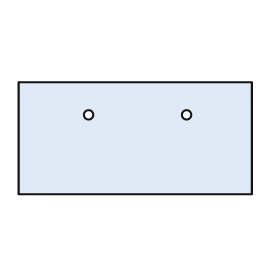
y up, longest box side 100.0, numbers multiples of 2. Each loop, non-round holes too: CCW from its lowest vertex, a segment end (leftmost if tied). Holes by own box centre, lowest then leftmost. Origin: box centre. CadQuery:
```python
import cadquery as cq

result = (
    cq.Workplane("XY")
    .moveTo(-50.0, -24.0)
    .lineTo(50.0, -24.0)
    .lineTo(50.0, 24.0)
    .lineTo(-50.0, 24.0)
    .close()
    .moveTo(-20.0, 10.0)
    .circle(2.0)
    .moveTo(22.0, 10.0)
    .circle(2.0)
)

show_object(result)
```